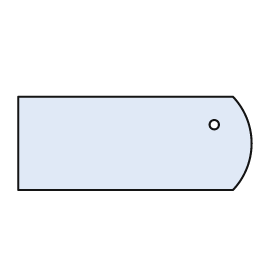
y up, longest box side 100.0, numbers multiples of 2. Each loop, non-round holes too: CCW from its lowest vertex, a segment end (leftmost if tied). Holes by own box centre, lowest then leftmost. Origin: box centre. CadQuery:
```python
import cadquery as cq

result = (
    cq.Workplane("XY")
    .moveTo(-50.0, -20.0)
    .lineTo(42.0, -20.0)
    .threePointArc((50.0, 0.0), (42.0, 20.0))
    .lineTo(-50.0, 20.0)
    .close()
    .moveTo(34.0, 8.0)
    .circle(2.0)
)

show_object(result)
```